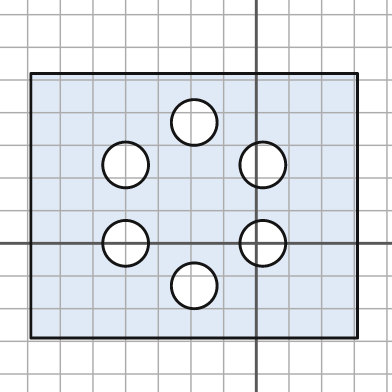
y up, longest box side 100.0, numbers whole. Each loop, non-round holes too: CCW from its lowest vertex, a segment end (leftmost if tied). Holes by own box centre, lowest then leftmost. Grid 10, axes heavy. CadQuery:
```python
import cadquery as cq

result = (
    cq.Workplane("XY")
    .moveTo(-69.0, -29.0)
    .lineTo(31.0, -29.0)
    .lineTo(31.0, 52.0)
    .lineTo(-69.0, 52.0)
    .close()
    .moveTo(-19.0, -13.0)
    .circle(7.0)
    .moveTo(-40.0, 0.0)
    .circle(7.0)
    .moveTo(2.0, 0.0)
    .circle(7.0)
    .moveTo(-40.0, 24.0)
    .circle(7.0)
    .moveTo(2.0, 24.0)
    .circle(7.0)
    .moveTo(-19.0, 37.0)
    .circle(7.0)
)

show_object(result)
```